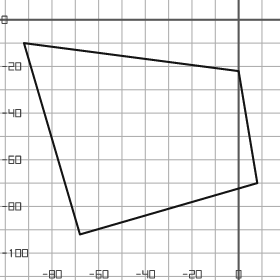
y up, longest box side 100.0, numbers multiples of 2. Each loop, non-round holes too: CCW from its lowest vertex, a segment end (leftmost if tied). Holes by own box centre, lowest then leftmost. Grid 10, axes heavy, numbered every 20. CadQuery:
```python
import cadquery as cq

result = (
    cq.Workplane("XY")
    .moveTo(-68.0, -92.0)
    .lineTo(8.0, -70.0)
    .lineTo(0.0, -22.0)
    .lineTo(-92.0, -10.0)
    .close()
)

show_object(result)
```